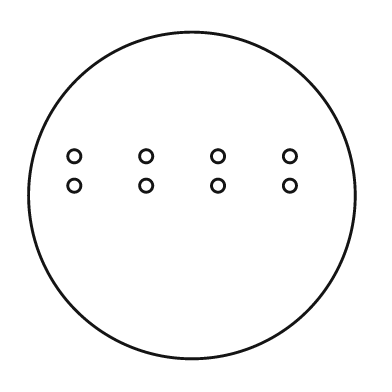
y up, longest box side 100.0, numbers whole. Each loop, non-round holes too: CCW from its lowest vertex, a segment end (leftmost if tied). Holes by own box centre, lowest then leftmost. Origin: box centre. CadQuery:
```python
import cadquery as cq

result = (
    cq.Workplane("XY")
    .moveTo(0.0, 0.0)
    .circle(50.0)
    .moveTo(-36.0, 3.0)
    .circle(2.0)
    .moveTo(-14.0, 3.0)
    .circle(2.0)
    .moveTo(8.0, 3.0)
    .circle(2.0)
    .moveTo(30.0, 3.0)
    .circle(2.0)
    .moveTo(-36.0, 12.0)
    .circle(2.0)
    .moveTo(-14.0, 12.0)
    .circle(2.0)
    .moveTo(8.0, 12.0)
    .circle(2.0)
    .moveTo(30.0, 12.0)
    .circle(2.0)
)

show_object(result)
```